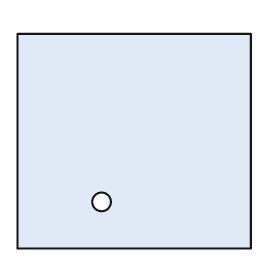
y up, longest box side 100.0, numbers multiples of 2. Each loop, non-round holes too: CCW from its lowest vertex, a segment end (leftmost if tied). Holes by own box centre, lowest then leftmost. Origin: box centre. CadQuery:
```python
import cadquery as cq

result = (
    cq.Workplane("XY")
    .moveTo(-50.0, -46.0)
    .lineTo(50.0, -46.0)
    .lineTo(50.0, 46.0)
    .lineTo(-50.0, 46.0)
    .close()
    .moveTo(-14.0, -26.0)
    .circle(4.0)
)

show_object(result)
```